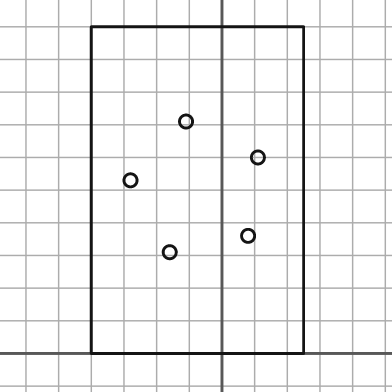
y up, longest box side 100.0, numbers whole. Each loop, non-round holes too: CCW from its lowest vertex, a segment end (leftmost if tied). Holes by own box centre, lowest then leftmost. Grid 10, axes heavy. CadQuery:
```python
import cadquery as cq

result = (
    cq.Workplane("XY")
    .moveTo(-40.0, 0.0)
    .lineTo(25.0, 0.0)
    .lineTo(25.0, 100.0)
    .lineTo(-40.0, 100.0)
    .close()
    .moveTo(-16.0, 31.0)
    .circle(2.0)
    .moveTo(8.0, 36.0)
    .circle(2.0)
    .moveTo(-28.0, 53.0)
    .circle(2.0)
    .moveTo(11.0, 60.0)
    .circle(2.0)
    .moveTo(-11.0, 71.0)
    .circle(2.0)
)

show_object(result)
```